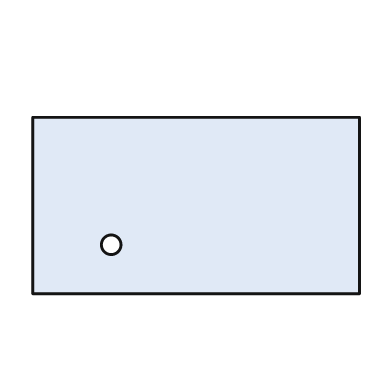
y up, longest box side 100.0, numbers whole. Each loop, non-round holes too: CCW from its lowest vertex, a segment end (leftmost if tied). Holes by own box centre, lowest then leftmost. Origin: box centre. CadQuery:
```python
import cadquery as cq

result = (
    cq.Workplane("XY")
    .moveTo(-50.0, -27.0)
    .lineTo(50.0, -27.0)
    .lineTo(50.0, 27.0)
    .lineTo(-50.0, 27.0)
    .close()
    .moveTo(-26.0, -12.0)
    .circle(3.0)
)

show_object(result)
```